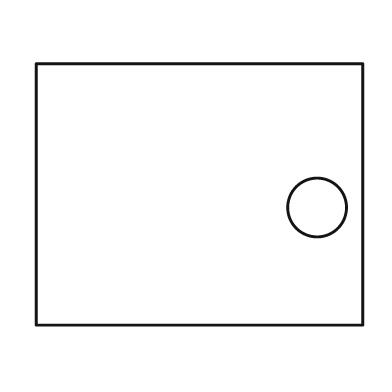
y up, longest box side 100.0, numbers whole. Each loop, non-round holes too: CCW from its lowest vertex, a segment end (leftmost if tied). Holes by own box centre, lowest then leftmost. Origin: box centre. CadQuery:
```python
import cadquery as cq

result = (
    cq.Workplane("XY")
    .moveTo(-50.0, -40.0)
    .lineTo(50.0, -40.0)
    .lineTo(50.0, 40.0)
    .lineTo(-50.0, 40.0)
    .close()
    .moveTo(36.0, -4.0)
    .circle(9.0)
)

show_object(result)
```